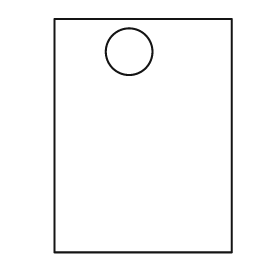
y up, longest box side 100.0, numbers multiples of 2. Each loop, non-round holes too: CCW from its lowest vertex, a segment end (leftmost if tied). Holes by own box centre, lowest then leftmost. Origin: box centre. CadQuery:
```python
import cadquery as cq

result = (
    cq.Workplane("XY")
    .moveTo(-38.0, -50.0)
    .lineTo(38.0, -50.0)
    .lineTo(38.0, 50.0)
    .lineTo(-38.0, 50.0)
    .close()
    .moveTo(-6.0, 36.0)
    .circle(10.0)
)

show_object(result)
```